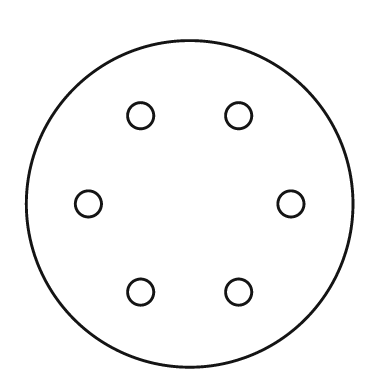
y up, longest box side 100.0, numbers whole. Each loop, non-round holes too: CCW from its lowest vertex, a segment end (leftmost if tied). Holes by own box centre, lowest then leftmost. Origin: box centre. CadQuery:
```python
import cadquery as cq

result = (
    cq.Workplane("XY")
    .moveTo(0.0, 0.0)
    .circle(50.0)
    .moveTo(-15.0, -27.0)
    .circle(4.0)
    .moveTo(15.0, -27.0)
    .circle(4.0)
    .moveTo(-31.0, 0.0)
    .circle(4.0)
    .moveTo(31.0, 0.0)
    .circle(4.0)
    .moveTo(-15.0, 27.0)
    .circle(4.0)
    .moveTo(15.0, 27.0)
    .circle(4.0)
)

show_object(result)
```